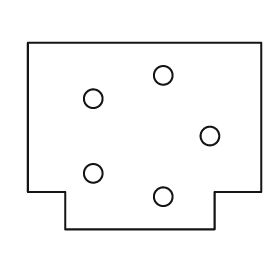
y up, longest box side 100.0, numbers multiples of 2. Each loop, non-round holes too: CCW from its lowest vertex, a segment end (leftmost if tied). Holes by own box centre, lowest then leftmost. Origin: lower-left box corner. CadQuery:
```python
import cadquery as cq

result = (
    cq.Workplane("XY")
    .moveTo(16.0, 0.0)
    .lineTo(80.0, 0.0)
    .lineTo(80.0, 16.0)
    .lineTo(100.0, 16.0)
    .lineTo(100.0, 80.0)
    .lineTo(0.0, 80.0)
    .lineTo(0.0, 16.0)
    .lineTo(16.0, 16.0)
    .close()
    .moveTo(58.0, 14.0)
    .circle(4.0)
    .moveTo(28.0, 24.0)
    .circle(4.0)
    .moveTo(78.0, 40.0)
    .circle(4.0)
    .moveTo(28.0, 56.0)
    .circle(4.0)
    .moveTo(58.0, 66.0)
    .circle(4.0)
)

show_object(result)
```